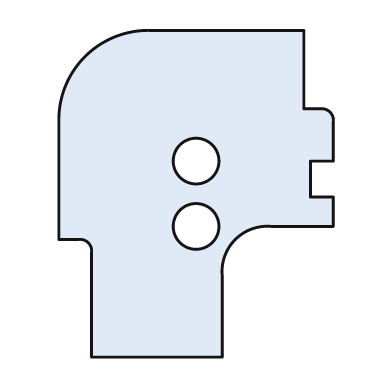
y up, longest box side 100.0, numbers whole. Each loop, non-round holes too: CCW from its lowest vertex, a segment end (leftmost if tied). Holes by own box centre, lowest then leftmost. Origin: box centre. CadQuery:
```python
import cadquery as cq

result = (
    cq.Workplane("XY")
    .moveTo(-32.0, -50.0)
    .lineTo(8.0, -50.0)
    .lineTo(8.0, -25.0)
    .threePointArc((12.0, -14.0), (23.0, -10.0))
    .lineTo(42.0, -10.0)
    .lineTo(42.0, -1.0)
    .lineTo(35.0, -1.0)
    .lineTo(35.0, 10.0)
    .lineTo(42.0, 10.0)
    .lineTo(42.0, 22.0)
    .threePointArc((41.0, 25.0), (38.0, 26.0))
    .lineTo(33.0, 26.0)
    .lineTo(33.0, 50.0)
    .lineTo(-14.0, 50.0)
    .threePointArc((-34.0, 42.0), (-42.0, 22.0))
    .lineTo(-42.0, -14.0)
    .lineTo(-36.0, -14.0)
    .threePointArc((-33.0, -15.0), (-32.0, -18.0))
    .close()
    .moveTo(0.0, -10.0)
    .circle(7.0)
    .moveTo(0.0, 10.0)
    .circle(7.0)
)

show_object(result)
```